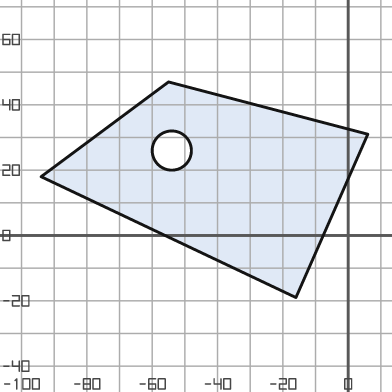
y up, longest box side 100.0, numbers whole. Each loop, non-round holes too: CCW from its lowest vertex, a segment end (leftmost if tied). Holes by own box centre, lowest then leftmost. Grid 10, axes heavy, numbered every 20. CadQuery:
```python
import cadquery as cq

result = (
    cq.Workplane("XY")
    .moveTo(-16.0, -19.0)
    .lineTo(6.0, 31.0)
    .lineTo(-55.0, 47.0)
    .lineTo(-94.0, 18.0)
    .close()
    .moveTo(-54.0, 26.0)
    .circle(6.0)
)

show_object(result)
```